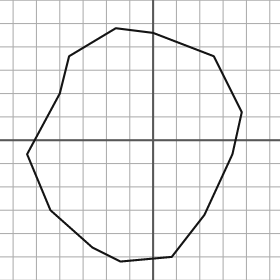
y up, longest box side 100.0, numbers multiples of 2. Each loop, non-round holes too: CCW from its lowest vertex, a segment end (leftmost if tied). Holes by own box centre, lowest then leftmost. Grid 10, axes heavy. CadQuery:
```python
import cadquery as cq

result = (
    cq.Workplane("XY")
    .moveTo(-14.0, -52.0)
    .lineTo(8.0, -50.0)
    .lineTo(22.0, -32.0)
    .lineTo(34.0, -6.0)
    .lineTo(38.0, 12.0)
    .lineTo(26.0, 36.0)
    .lineTo(0.0, 46.0)
    .lineTo(-16.0, 48.0)
    .lineTo(-36.0, 36.0)
    .lineTo(-40.0, 20.0)
    .lineTo(-54.0, -6.0)
    .lineTo(-44.0, -30.0)
    .lineTo(-26.0, -46.0)
    .close()
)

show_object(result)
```